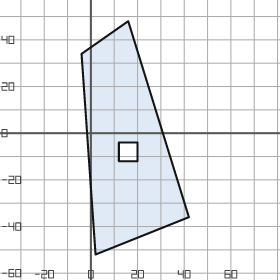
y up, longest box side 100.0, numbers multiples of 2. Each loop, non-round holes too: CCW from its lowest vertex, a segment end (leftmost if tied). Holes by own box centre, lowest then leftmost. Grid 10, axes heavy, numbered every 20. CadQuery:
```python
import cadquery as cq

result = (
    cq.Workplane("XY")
    .moveTo(2.0, -52.0)
    .lineTo(42.0, -36.0)
    .lineTo(16.0, 48.0)
    .lineTo(-4.0, 34.0)
    .close()
    .moveTo(12.0, -12.0)
    .lineTo(20.0, -12.0)
    .lineTo(20.0, -4.0)
    .lineTo(12.0, -4.0)
    .close()
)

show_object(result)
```